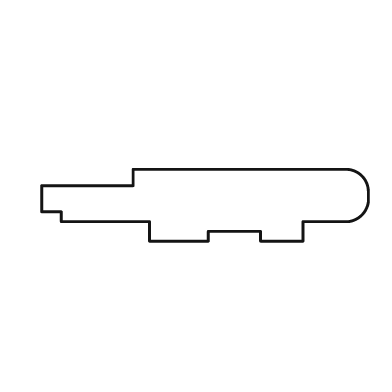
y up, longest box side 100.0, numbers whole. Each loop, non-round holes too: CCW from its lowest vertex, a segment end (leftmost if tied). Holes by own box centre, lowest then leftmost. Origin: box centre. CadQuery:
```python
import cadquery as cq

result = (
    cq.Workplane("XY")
    .moveTo(-17.0, -11.0)
    .lineTo(1.0, -11.0)
    .lineTo(1.0, -8.0)
    .lineTo(17.0, -8.0)
    .lineTo(17.0, -11.0)
    .lineTo(30.0, -11.0)
    .lineTo(30.0, -5.0)
    .lineTo(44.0, -5.0)
    .threePointArc((48.0, -3.0), (50.0, 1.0))
    .lineTo(50.0, 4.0)
    .threePointArc((48.0, 9.0), (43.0, 11.0))
    .lineTo(-22.0, 11.0)
    .lineTo(-22.0, 6.0)
    .lineTo(-50.0, 6.0)
    .lineTo(-50.0, -2.0)
    .lineTo(-44.0, -2.0)
    .lineTo(-44.0, -5.0)
    .lineTo(-17.0, -5.0)
    .close()
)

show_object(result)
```